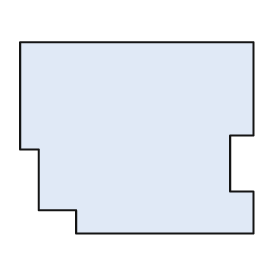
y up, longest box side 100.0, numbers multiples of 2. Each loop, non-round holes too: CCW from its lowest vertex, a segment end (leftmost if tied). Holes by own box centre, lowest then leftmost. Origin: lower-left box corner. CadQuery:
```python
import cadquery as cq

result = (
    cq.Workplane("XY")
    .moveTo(24.0, 0.0)
    .lineTo(100.0, 0.0)
    .lineTo(100.0, 18.0)
    .lineTo(90.0, 18.0)
    .lineTo(90.0, 42.0)
    .lineTo(100.0, 42.0)
    .lineTo(100.0, 82.0)
    .lineTo(0.0, 82.0)
    .lineTo(0.0, 36.0)
    .lineTo(8.0, 36.0)
    .lineTo(8.0, 10.0)
    .lineTo(24.0, 10.0)
    .close()
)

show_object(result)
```